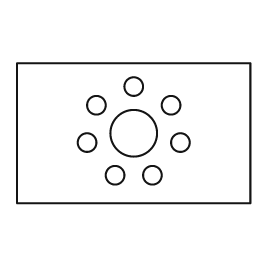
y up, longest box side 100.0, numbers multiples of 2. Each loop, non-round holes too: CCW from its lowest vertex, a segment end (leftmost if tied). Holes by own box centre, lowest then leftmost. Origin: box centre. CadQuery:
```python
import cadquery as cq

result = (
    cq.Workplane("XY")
    .moveTo(-50.0, -30.0)
    .lineTo(50.0, -30.0)
    .lineTo(50.0, 30.0)
    .lineTo(-50.0, 30.0)
    .close()
    .moveTo(-8.0, -18.0)
    .circle(4.0)
    .moveTo(8.0, -18.0)
    .circle(4.0)
    .moveTo(-20.0, -4.0)
    .circle(4.0)
    .moveTo(20.0, -4.0)
    .circle(4.0)
    .moveTo(0.0, 0.0)
    .circle(10.0)
    .moveTo(-16.0, 12.0)
    .circle(4.0)
    .moveTo(16.0, 12.0)
    .circle(4.0)
    .moveTo(0.0, 20.0)
    .circle(4.0)
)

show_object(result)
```